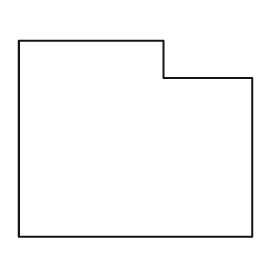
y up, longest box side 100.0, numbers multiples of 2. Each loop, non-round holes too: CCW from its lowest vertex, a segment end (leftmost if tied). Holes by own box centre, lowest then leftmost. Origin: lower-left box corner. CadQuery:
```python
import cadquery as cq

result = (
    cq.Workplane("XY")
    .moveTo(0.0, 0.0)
    .lineTo(100.0, 0.0)
    .lineTo(100.0, 68.0)
    .lineTo(62.0, 68.0)
    .lineTo(62.0, 84.0)
    .lineTo(0.0, 84.0)
    .close()
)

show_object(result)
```